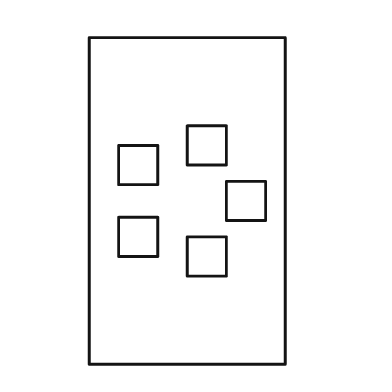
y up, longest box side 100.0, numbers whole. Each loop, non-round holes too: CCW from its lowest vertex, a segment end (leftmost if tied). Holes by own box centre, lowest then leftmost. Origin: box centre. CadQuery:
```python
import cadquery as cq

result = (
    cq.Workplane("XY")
    .moveTo(-30.0, -50.0)
    .lineTo(30.0, -50.0)
    .lineTo(30.0, 50.0)
    .lineTo(-30.0, 50.0)
    .close()
    .moveTo(0.0, -23.0)
    .lineTo(12.0, -23.0)
    .lineTo(12.0, -11.0)
    .lineTo(0.0, -11.0)
    .close()
    .moveTo(-21.0, -17.0)
    .lineTo(-9.0, -17.0)
    .lineTo(-9.0, -5.0)
    .lineTo(-21.0, -5.0)
    .close()
    .moveTo(12.0, -6.0)
    .lineTo(24.0, -6.0)
    .lineTo(24.0, 6.0)
    .lineTo(12.0, 6.0)
    .close()
    .moveTo(-21.0, 5.0)
    .lineTo(-9.0, 5.0)
    .lineTo(-9.0, 17.0)
    .lineTo(-21.0, 17.0)
    .close()
    .moveTo(0.0, 11.0)
    .lineTo(12.0, 11.0)
    .lineTo(12.0, 23.0)
    .lineTo(0.0, 23.0)
    .close()
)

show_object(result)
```